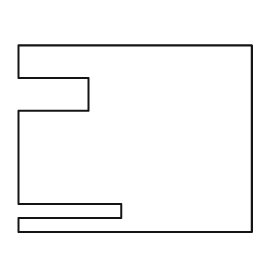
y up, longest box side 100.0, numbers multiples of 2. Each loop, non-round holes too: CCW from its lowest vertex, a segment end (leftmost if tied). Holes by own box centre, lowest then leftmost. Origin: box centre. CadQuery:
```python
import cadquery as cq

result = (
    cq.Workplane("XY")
    .moveTo(-50.0, -40.0)
    .lineTo(50.0, -40.0)
    .lineTo(50.0, 40.0)
    .lineTo(-50.0, 40.0)
    .lineTo(-50.0, 26.0)
    .lineTo(-20.0, 26.0)
    .lineTo(-20.0, 12.0)
    .lineTo(-50.0, 12.0)
    .lineTo(-50.0, -28.0)
    .lineTo(-6.0, -28.0)
    .lineTo(-6.0, -34.0)
    .lineTo(-50.0, -34.0)
    .close()
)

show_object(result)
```